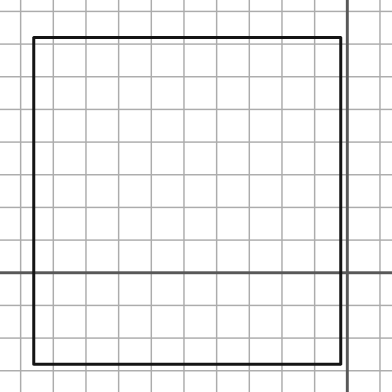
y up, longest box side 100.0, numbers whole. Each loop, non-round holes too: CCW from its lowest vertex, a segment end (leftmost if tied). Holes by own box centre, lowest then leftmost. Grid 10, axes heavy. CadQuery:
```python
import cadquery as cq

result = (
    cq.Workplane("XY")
    .moveTo(-96.0, -28.0)
    .lineTo(-2.0, -28.0)
    .lineTo(-2.0, 72.0)
    .lineTo(-96.0, 72.0)
    .close()
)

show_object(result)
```